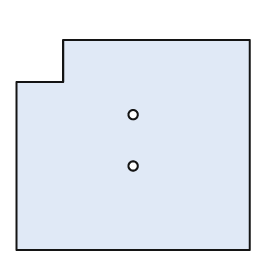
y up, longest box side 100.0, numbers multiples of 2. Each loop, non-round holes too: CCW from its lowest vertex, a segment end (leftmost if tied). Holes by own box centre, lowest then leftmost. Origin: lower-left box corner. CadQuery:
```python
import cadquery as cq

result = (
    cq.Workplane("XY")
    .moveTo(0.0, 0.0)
    .lineTo(100.0, 0.0)
    .lineTo(100.0, 90.0)
    .lineTo(20.0, 90.0)
    .lineTo(20.0, 72.0)
    .lineTo(0.0, 72.0)
    .close()
    .moveTo(50.0, 36.0)
    .circle(2.0)
    .moveTo(50.0, 58.0)
    .circle(2.0)
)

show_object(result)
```